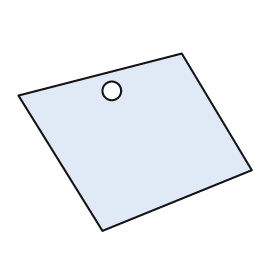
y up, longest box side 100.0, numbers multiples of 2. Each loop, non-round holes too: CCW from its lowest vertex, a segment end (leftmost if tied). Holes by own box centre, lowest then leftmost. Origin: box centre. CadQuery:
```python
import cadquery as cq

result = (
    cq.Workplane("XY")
    .moveTo(-14.0, -38.0)
    .lineTo(50.0, -12.0)
    .lineTo(20.0, 38.0)
    .lineTo(-50.0, 20.0)
    .close()
    .moveTo(-10.0, 22.0)
    .circle(4.0)
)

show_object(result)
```